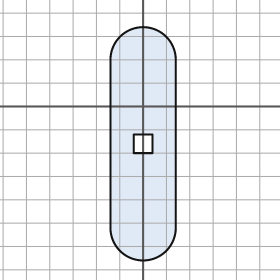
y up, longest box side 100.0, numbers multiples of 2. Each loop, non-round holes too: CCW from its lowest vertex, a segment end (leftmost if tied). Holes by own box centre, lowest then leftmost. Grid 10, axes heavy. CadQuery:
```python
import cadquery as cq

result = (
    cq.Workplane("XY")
    .moveTo(-14.0, -52.0)
    .threePointArc((0.0, -66.0), (14.0, -52.0))
    .lineTo(14.0, 20.0)
    .threePointArc((0.0, 34.0), (-14.0, 20.0))
    .close()
    .moveTo(-4.0, -20.0)
    .lineTo(4.0, -20.0)
    .lineTo(4.0, -12.0)
    .lineTo(-4.0, -12.0)
    .close()
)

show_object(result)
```